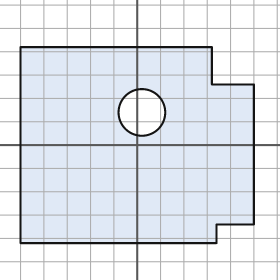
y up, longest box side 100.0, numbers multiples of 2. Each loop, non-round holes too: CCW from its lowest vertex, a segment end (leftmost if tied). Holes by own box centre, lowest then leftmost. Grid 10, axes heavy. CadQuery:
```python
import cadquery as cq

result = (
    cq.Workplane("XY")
    .moveTo(-50.0, -42.0)
    .lineTo(34.0, -42.0)
    .lineTo(34.0, -34.0)
    .lineTo(50.0, -34.0)
    .lineTo(50.0, 26.0)
    .lineTo(32.0, 26.0)
    .lineTo(32.0, 42.0)
    .lineTo(-50.0, 42.0)
    .close()
    .moveTo(2.0, 14.0)
    .circle(10.0)
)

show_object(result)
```